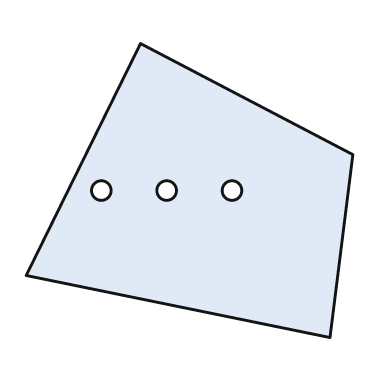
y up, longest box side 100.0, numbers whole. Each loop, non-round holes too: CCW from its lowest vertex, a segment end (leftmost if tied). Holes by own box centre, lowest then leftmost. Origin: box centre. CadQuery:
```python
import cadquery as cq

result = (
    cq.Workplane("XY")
    .moveTo(43.0, -45.0)
    .lineTo(50.0, 11.0)
    .lineTo(-15.0, 45.0)
    .lineTo(-50.0, -26.0)
    .close()
    .moveTo(-27.0, 0.0)
    .circle(3.0)
    .moveTo(-7.0, 0.0)
    .circle(3.0)
    .moveTo(13.0, 0.0)
    .circle(3.0)
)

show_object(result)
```